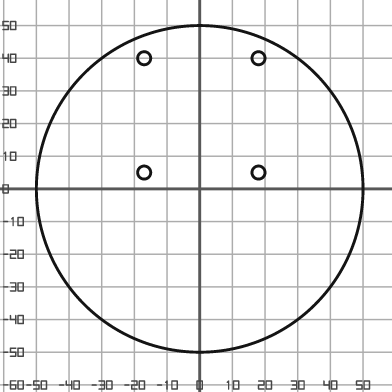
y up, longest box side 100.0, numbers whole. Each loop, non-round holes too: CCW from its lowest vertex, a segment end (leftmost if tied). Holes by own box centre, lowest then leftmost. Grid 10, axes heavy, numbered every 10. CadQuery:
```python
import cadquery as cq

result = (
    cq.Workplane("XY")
    .moveTo(0.0, 0.0)
    .circle(50.0)
    .moveTo(-17.0, 5.0)
    .circle(2.0)
    .moveTo(18.0, 5.0)
    .circle(2.0)
    .moveTo(-17.0, 40.0)
    .circle(2.0)
    .moveTo(18.0, 40.0)
    .circle(2.0)
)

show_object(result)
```